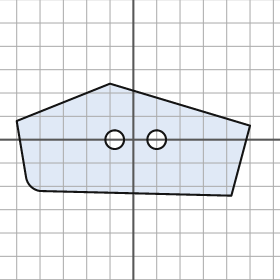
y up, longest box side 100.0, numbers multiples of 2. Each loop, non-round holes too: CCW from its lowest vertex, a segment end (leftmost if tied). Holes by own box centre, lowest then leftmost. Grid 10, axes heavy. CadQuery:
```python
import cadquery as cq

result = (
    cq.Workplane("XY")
    .moveTo(42.0, -24.0)
    .lineTo(50.0, 6.0)
    .lineTo(-10.0, 24.0)
    .lineTo(-50.0, 8.0)
    .lineTo(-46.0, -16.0)
    .threePointArc((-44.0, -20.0), (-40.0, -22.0))
    .close()
    .moveTo(-8.0, 0.0)
    .circle(4.0)
    .moveTo(10.0, 0.0)
    .circle(4.0)
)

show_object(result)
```